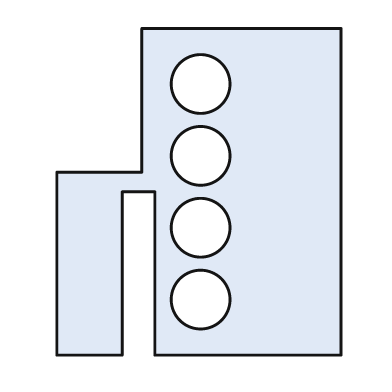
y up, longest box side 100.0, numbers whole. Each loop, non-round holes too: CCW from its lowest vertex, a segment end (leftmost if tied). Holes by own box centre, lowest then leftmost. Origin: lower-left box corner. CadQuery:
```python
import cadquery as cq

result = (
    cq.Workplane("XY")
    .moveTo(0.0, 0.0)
    .lineTo(20.0, 0.0)
    .lineTo(20.0, 50.0)
    .lineTo(30.0, 50.0)
    .lineTo(30.0, 0.0)
    .lineTo(87.0, 0.0)
    .lineTo(87.0, 100.0)
    .lineTo(26.0, 100.0)
    .lineTo(26.0, 56.0)
    .lineTo(0.0, 56.0)
    .close()
    .moveTo(44.0, 17.0)
    .circle(9.0)
    .moveTo(44.0, 39.0)
    .circle(9.0)
    .moveTo(44.0, 61.0)
    .circle(9.0)
    .moveTo(44.0, 83.0)
    .circle(9.0)
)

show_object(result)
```